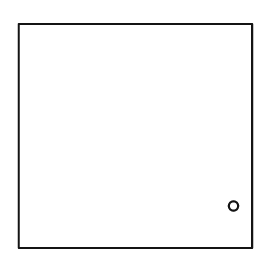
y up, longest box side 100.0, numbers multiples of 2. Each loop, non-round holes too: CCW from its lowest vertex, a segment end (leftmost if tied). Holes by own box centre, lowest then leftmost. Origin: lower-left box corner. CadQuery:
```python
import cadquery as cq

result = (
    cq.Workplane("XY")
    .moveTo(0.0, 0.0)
    .lineTo(100.0, 0.0)
    .lineTo(100.0, 96.0)
    .lineTo(0.0, 96.0)
    .close()
    .moveTo(92.0, 18.0)
    .circle(2.0)
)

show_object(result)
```